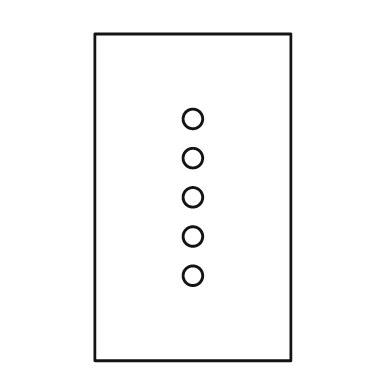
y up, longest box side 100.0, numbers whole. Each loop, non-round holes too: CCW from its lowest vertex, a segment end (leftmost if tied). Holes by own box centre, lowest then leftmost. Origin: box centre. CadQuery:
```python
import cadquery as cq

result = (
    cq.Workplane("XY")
    .moveTo(-30.0, -50.0)
    .lineTo(30.0, -50.0)
    .lineTo(30.0, 50.0)
    .lineTo(-30.0, 50.0)
    .close()
    .moveTo(0.0, -24.0)
    .circle(3.0)
    .moveTo(0.0, -12.0)
    .circle(3.0)
    .moveTo(0.0, 0.0)
    .circle(3.0)
    .moveTo(0.0, 12.0)
    .circle(3.0)
    .moveTo(0.0, 24.0)
    .circle(3.0)
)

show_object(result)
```